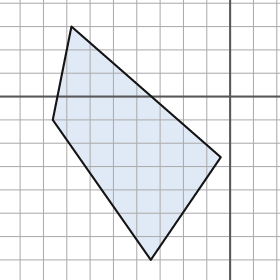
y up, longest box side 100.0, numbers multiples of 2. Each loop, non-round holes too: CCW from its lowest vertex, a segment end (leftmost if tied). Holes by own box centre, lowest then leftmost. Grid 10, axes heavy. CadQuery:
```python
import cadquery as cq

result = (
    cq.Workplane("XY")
    .moveTo(-34.0, -70.0)
    .lineTo(-4.0, -26.0)
    .lineTo(-68.0, 30.0)
    .lineTo(-76.0, -10.0)
    .close()
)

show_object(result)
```